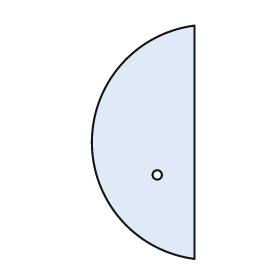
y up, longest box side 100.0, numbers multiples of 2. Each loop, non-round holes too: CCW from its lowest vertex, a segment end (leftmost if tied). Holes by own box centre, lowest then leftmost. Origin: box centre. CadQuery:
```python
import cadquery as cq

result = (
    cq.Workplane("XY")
    .moveTo(22.0, -50.0)
    .lineTo(22.0, 50.0)
    .threePointArc((-22.0, 0.0), (22.0, -50.0))
    .close()
    .moveTo(6.0, -14.0)
    .circle(2.0)
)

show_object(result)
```